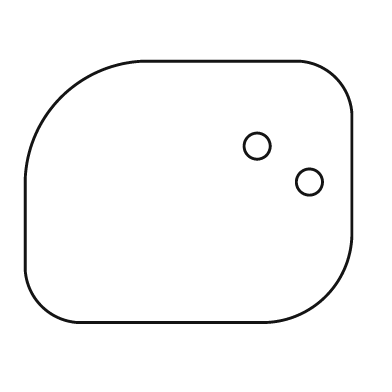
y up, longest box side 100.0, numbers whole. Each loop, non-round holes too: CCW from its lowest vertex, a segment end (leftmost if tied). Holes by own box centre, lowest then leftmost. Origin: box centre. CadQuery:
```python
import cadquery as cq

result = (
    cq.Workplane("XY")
    .moveTo(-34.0, -40.0)
    .lineTo(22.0, -40.0)
    .threePointArc((42.0, -32.0), (50.0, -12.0))
    .lineTo(50.0, 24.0)
    .threePointArc((45.0, 35.0), (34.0, 40.0))
    .lineTo(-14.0, 40.0)
    .threePointArc((-39.0, 29.0), (-50.0, 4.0))
    .lineTo(-50.0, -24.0)
    .threePointArc((-45.0, -35.0), (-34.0, -40.0))
    .close()
    .moveTo(37.0, 3.0)
    .circle(4.0)
    .moveTo(21.0, 14.0)
    .circle(4.0)
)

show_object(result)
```